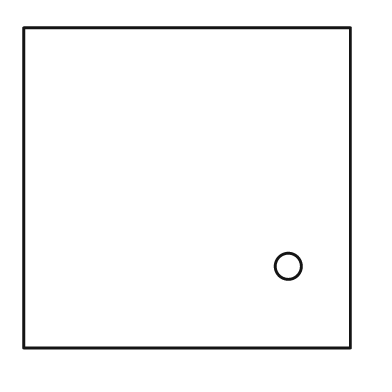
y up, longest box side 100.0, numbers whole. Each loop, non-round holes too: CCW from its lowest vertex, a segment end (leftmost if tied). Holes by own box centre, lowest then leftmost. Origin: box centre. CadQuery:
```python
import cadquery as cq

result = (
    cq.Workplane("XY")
    .moveTo(-50.0, -49.0)
    .lineTo(50.0, -49.0)
    .lineTo(50.0, 49.0)
    .lineTo(-50.0, 49.0)
    .close()
    .moveTo(31.0, -24.0)
    .circle(4.0)
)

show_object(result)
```